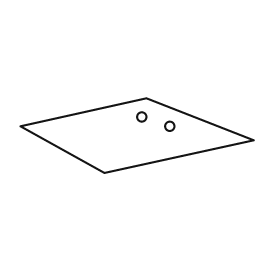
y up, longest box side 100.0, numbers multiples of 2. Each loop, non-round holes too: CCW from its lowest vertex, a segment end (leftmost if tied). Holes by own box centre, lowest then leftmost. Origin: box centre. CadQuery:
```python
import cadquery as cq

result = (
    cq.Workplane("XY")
    .moveTo(-14.0, -16.0)
    .lineTo(50.0, -2.0)
    .lineTo(4.0, 16.0)
    .lineTo(-50.0, 4.0)
    .close()
    .moveTo(14.0, 4.0)
    .circle(2.0)
    .moveTo(2.0, 8.0)
    .circle(2.0)
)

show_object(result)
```